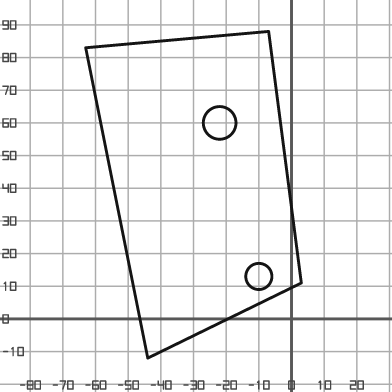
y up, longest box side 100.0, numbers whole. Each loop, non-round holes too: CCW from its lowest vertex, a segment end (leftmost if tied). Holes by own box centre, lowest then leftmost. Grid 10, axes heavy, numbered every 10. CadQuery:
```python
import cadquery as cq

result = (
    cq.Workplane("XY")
    .moveTo(-44.0, -12.0)
    .lineTo(3.0, 11.0)
    .lineTo(-7.0, 88.0)
    .lineTo(-63.0, 83.0)
    .close()
    .moveTo(-10.0, 13.0)
    .circle(4.0)
    .moveTo(-22.0, 60.0)
    .circle(5.0)
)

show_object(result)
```